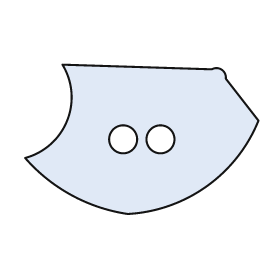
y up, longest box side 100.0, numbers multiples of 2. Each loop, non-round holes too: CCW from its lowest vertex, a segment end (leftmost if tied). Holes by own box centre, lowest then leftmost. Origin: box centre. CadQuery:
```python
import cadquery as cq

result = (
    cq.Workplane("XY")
    .moveTo(-6.0, -32.0)
    .threePointArc((28.0, -20.0), (50.0, 8.0))
    .lineTo(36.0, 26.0)
    .threePointArc((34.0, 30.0), (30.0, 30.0))
    .lineTo(-34.0, 32.0)
    .threePointArc((-32.0, 8.0), (-50.0, -8.0))
    .threePointArc((-30.0, -24.0), (-6.0, -32.0))
    .close()
    .moveTo(-8.0, 0.0)
    .circle(6.0)
    .moveTo(8.0, 0.0)
    .circle(6.0)
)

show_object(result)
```